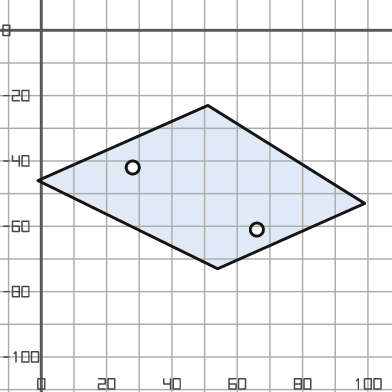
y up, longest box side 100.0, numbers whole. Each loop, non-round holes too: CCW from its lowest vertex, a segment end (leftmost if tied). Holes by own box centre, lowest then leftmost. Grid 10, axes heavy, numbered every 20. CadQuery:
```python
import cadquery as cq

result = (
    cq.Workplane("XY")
    .moveTo(54.0, -73.0)
    .lineTo(99.0, -53.0)
    .lineTo(51.0, -23.0)
    .lineTo(-1.0, -46.0)
    .close()
    .moveTo(66.0, -61.0)
    .circle(2.0)
    .moveTo(28.0, -42.0)
    .circle(2.0)
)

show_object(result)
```